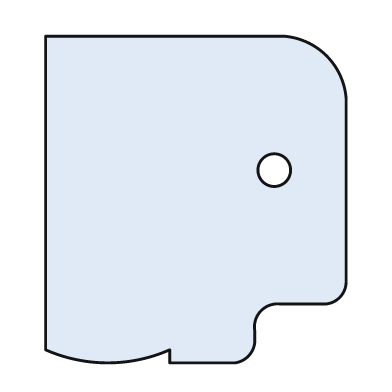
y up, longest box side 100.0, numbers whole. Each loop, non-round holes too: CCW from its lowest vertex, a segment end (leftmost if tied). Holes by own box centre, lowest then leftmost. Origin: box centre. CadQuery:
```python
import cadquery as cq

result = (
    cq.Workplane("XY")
    .moveTo(-8.0, -50.0)
    .lineTo(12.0, -50.0)
    .threePointArc((16.0, -48.0), (18.0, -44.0))
    .lineTo(18.0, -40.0)
    .threePointArc((20.0, -34.0), (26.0, -32.0))
    .lineTo(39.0, -32.0)
    .threePointArc((44.0, -30.0), (46.0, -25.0))
    .lineTo(46.0, 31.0)
    .threePointArc((40.0, 44.0), (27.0, 50.0))
    .lineTo(-46.0, 50.0)
    .lineTo(-46.0, -46.0)
    .threePointArc((-27.0, -50.0), (-8.0, -46.0))
    .close()
    .moveTo(24.0, 9.0)
    .circle(5.0)
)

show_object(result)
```